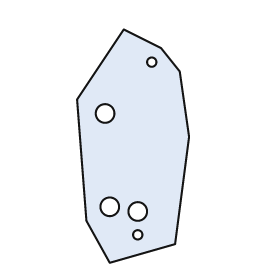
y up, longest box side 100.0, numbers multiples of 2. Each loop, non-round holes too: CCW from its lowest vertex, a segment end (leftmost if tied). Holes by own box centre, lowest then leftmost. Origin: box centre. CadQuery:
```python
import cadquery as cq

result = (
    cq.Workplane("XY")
    .moveTo(-10.0, -50.0)
    .lineTo(18.0, -42.0)
    .lineTo(24.0, 4.0)
    .lineTo(20.0, 32.0)
    .lineTo(12.0, 42.0)
    .lineTo(-4.0, 50.0)
    .lineTo(-24.0, 20.0)
    .lineTo(-20.0, -32.0)
    .close()
    .moveTo(2.0, -38.0)
    .circle(2.0)
    .moveTo(2.0, -28.0)
    .circle(4.0)
    .moveTo(-10.0, -26.0)
    .circle(4.0)
    .moveTo(-12.0, 14.0)
    .circle(4.0)
    .moveTo(8.0, 36.0)
    .circle(2.0)
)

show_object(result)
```